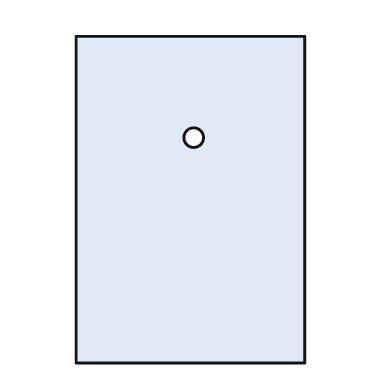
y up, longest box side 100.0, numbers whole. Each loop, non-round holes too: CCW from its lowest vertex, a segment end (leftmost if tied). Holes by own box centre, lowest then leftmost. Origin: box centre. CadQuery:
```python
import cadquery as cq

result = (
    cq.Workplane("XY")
    .moveTo(-35.0, -50.0)
    .lineTo(35.0, -50.0)
    .lineTo(35.0, 50.0)
    .lineTo(-35.0, 50.0)
    .close()
    .moveTo(1.0, 19.0)
    .circle(3.0)
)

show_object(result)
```